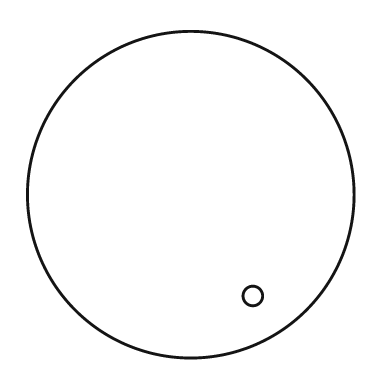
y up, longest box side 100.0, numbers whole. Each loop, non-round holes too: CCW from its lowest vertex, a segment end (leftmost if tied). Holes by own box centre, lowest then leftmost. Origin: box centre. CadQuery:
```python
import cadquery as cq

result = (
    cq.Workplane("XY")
    .moveTo(0.0, 0.0)
    .circle(50.0)
    .moveTo(19.0, -31.0)
    .circle(3.0)
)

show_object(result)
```